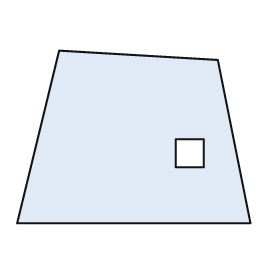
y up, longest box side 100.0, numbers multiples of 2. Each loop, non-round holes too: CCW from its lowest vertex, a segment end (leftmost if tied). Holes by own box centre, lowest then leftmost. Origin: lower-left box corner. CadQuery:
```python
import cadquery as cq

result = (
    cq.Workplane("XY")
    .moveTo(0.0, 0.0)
    .lineTo(100.0, 0.0)
    .lineTo(86.0, 70.0)
    .lineTo(18.0, 74.0)
    .close()
    .moveTo(68.0, 24.0)
    .lineTo(80.0, 24.0)
    .lineTo(80.0, 36.0)
    .lineTo(68.0, 36.0)
    .close()
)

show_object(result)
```